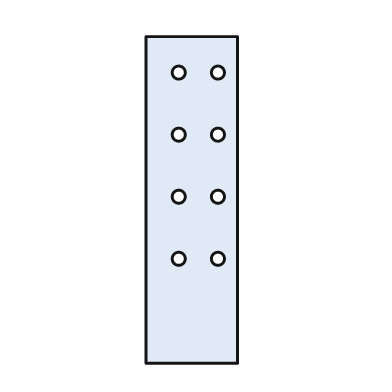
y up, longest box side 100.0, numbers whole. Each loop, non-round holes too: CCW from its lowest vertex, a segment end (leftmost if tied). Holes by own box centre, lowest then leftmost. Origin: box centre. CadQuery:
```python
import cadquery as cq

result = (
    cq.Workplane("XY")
    .moveTo(-14.0, -50.0)
    .lineTo(14.0, -50.0)
    .lineTo(14.0, 50.0)
    .lineTo(-14.0, 50.0)
    .close()
    .moveTo(-4.0, -18.0)
    .circle(2.0)
    .moveTo(8.0, -18.0)
    .circle(2.0)
    .moveTo(-4.0, 1.0)
    .circle(2.0)
    .moveTo(8.0, 1.0)
    .circle(2.0)
    .moveTo(-4.0, 20.0)
    .circle(2.0)
    .moveTo(8.0, 20.0)
    .circle(2.0)
    .moveTo(-4.0, 39.0)
    .circle(2.0)
    .moveTo(8.0, 39.0)
    .circle(2.0)
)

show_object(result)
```